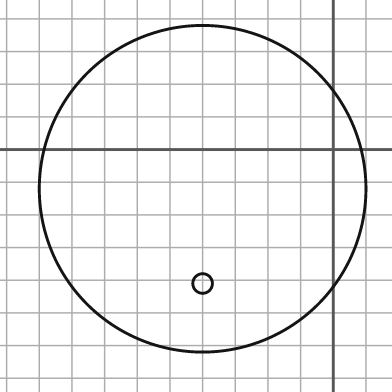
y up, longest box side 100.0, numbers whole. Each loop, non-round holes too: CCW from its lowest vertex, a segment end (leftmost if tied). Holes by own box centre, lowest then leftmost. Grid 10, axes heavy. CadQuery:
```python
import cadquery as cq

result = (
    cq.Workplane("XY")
    .moveTo(-40.0, -12.0)
    .circle(50.0)
    .moveTo(-40.0, -41.0)
    .circle(3.0)
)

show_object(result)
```